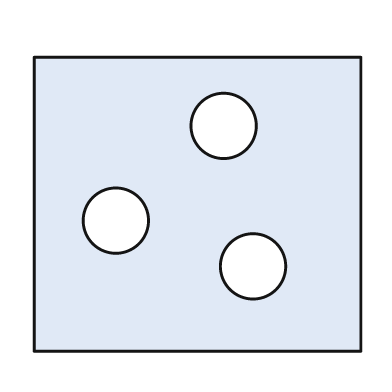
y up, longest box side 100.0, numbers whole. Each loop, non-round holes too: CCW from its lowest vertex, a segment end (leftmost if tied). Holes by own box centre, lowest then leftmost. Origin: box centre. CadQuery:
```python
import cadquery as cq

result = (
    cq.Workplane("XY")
    .moveTo(-50.0, -45.0)
    .lineTo(50.0, -45.0)
    .lineTo(50.0, 45.0)
    .lineTo(-50.0, 45.0)
    .close()
    .moveTo(17.0, -19.0)
    .circle(10.0)
    .moveTo(-25.0, -5.0)
    .circle(10.0)
    .moveTo(8.0, 24.0)
    .circle(10.0)
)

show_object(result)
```